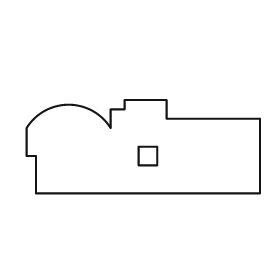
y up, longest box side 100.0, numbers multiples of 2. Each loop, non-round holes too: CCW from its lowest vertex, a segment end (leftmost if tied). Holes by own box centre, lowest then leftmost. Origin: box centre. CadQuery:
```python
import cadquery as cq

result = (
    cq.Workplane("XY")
    .moveTo(-46.0, -20.0)
    .lineTo(50.0, -20.0)
    .lineTo(50.0, 12.0)
    .lineTo(10.0, 12.0)
    .lineTo(10.0, 20.0)
    .lineTo(-8.0, 20.0)
    .lineTo(-8.0, 16.0)
    .lineTo(-14.0, 16.0)
    .lineTo(-14.0, 8.0)
    .threePointArc((-32.0, 18.0), (-50.0, 8.0))
    .lineTo(-50.0, -4.0)
    .lineTo(-46.0, -4.0)
    .close()
    .moveTo(-2.0, -8.0)
    .lineTo(6.0, -8.0)
    .lineTo(6.0, 0.0)
    .lineTo(-2.0, 0.0)
    .close()
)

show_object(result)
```